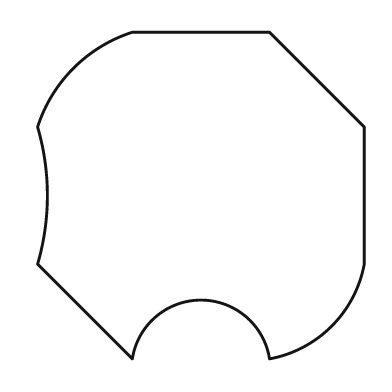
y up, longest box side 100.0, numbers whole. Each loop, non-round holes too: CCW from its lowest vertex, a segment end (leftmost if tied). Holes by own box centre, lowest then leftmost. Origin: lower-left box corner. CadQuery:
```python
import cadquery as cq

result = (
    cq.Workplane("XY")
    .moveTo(29.0, 0.0)
    .threePointArc((50.0, 18.0), (71.0, 0.0))
    .threePointArc((90.0, 10.0), (100.0, 29.0))
    .lineTo(100.0, 71.0)
    .lineTo(71.0, 100.0)
    .lineTo(29.0, 100.0)
    .threePointArc((11.0, 89.0), (0.0, 71.0))
    .threePointArc((3.0, 50.0), (0.0, 29.0))
    .close()
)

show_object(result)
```